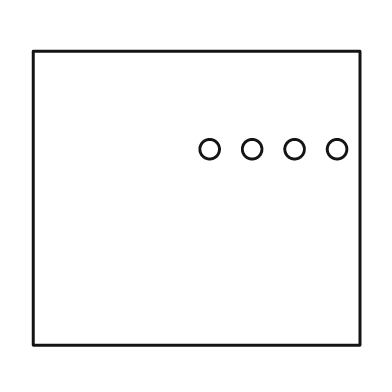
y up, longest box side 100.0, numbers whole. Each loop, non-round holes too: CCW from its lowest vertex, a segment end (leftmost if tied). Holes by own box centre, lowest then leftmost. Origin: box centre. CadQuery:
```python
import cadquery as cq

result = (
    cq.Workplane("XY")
    .moveTo(-50.0, -45.0)
    .lineTo(50.0, -45.0)
    .lineTo(50.0, 45.0)
    .lineTo(-50.0, 45.0)
    .close()
    .moveTo(4.0, 15.0)
    .circle(3.0)
    .moveTo(17.0, 15.0)
    .circle(3.0)
    .moveTo(30.0, 15.0)
    .circle(3.0)
    .moveTo(43.0, 15.0)
    .circle(3.0)
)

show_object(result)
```